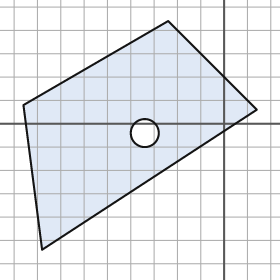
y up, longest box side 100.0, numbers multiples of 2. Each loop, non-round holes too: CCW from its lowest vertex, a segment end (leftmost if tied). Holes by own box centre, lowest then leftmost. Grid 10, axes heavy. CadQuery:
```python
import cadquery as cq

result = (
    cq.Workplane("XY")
    .moveTo(-78.0, -54.0)
    .lineTo(14.0, 6.0)
    .lineTo(-24.0, 44.0)
    .lineTo(-86.0, 8.0)
    .close()
    .moveTo(-34.0, -4.0)
    .circle(6.0)
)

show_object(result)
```